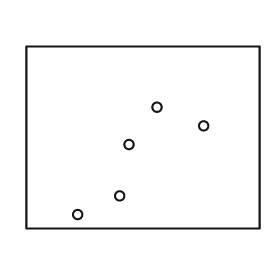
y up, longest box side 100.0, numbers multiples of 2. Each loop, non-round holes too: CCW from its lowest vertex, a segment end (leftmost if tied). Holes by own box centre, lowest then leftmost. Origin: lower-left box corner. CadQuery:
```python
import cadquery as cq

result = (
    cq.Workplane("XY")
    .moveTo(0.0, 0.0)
    .lineTo(100.0, 0.0)
    .lineTo(100.0, 78.0)
    .lineTo(0.0, 78.0)
    .close()
    .moveTo(22.0, 6.0)
    .circle(2.0)
    .moveTo(40.0, 14.0)
    .circle(2.0)
    .moveTo(44.0, 36.0)
    .circle(2.0)
    .moveTo(76.0, 44.0)
    .circle(2.0)
    .moveTo(56.0, 52.0)
    .circle(2.0)
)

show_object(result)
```